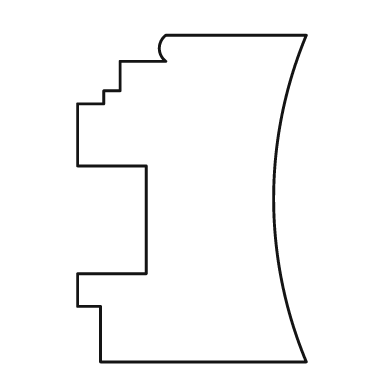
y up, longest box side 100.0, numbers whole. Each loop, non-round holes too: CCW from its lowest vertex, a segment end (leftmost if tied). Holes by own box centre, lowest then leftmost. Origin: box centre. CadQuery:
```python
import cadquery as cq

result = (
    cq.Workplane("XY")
    .moveTo(-28.0, -50.0)
    .lineTo(35.0, -50.0)
    .threePointArc((25.0, 0.0), (35.0, 50.0))
    .lineTo(-8.0, 50.0)
    .threePointArc((-10.0, 46.0), (-8.0, 42.0))
    .lineTo(-22.0, 42.0)
    .lineTo(-22.0, 33.0)
    .lineTo(-27.0, 33.0)
    .lineTo(-27.0, 29.0)
    .lineTo(-35.0, 29.0)
    .lineTo(-35.0, 10.0)
    .lineTo(-14.0, 10.0)
    .lineTo(-14.0, -23.0)
    .lineTo(-35.0, -23.0)
    .lineTo(-35.0, -33.0)
    .lineTo(-28.0, -33.0)
    .close()
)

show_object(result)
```